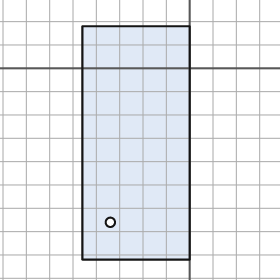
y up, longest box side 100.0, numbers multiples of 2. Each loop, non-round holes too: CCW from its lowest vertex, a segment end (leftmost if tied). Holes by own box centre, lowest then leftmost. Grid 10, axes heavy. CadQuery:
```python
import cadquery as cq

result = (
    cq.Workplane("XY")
    .moveTo(-46.0, -82.0)
    .lineTo(0.0, -82.0)
    .lineTo(0.0, 18.0)
    .lineTo(-46.0, 18.0)
    .close()
    .moveTo(-34.0, -66.0)
    .circle(2.0)
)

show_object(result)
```